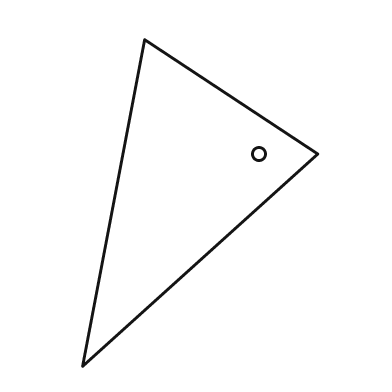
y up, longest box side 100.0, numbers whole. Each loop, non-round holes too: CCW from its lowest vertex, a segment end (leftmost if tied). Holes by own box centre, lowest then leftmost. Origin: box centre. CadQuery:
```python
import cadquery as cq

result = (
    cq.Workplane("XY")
    .moveTo(-36.0, -50.0)
    .lineTo(36.0, 15.0)
    .lineTo(-17.0, 50.0)
    .close()
    .moveTo(18.0, 15.0)
    .circle(2.0)
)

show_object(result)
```